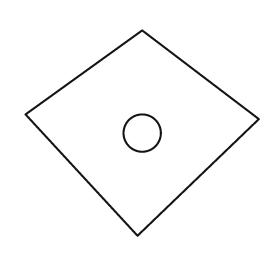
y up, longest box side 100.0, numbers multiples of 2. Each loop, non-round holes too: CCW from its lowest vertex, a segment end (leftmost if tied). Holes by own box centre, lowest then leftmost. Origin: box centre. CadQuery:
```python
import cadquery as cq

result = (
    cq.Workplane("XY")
    .moveTo(-2.0, -44.0)
    .lineTo(50.0, 6.0)
    .lineTo(0.0, 44.0)
    .lineTo(-50.0, 8.0)
    .close()
    .moveTo(0.0, 0.0)
    .circle(8.0)
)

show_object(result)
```